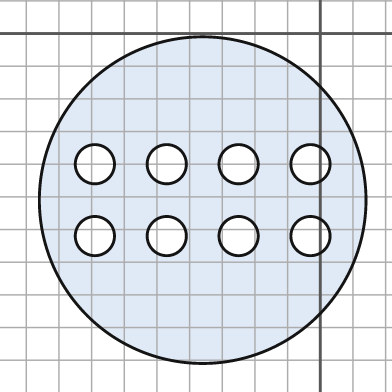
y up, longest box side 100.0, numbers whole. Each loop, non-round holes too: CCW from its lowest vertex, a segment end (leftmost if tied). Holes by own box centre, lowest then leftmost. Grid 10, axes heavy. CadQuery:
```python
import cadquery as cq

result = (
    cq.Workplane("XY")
    .moveTo(-36.0, -51.0)
    .circle(50.0)
    .moveTo(-69.0, -62.0)
    .circle(6.0)
    .moveTo(-47.0, -62.0)
    .circle(6.0)
    .moveTo(-25.0, -62.0)
    .circle(6.0)
    .moveTo(-3.0, -62.0)
    .circle(6.0)
    .moveTo(-69.0, -40.0)
    .circle(6.0)
    .moveTo(-47.0, -40.0)
    .circle(6.0)
    .moveTo(-25.0, -40.0)
    .circle(6.0)
    .moveTo(-3.0, -40.0)
    .circle(6.0)
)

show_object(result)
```